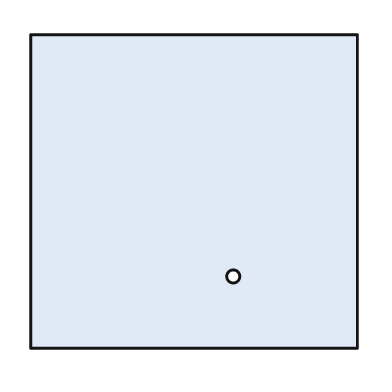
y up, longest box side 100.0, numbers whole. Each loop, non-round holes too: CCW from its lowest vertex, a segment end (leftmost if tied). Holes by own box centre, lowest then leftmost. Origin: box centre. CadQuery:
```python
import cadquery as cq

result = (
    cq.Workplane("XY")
    .moveTo(-50.0, -48.0)
    .lineTo(50.0, -48.0)
    .lineTo(50.0, 48.0)
    .lineTo(-50.0, 48.0)
    .close()
    .moveTo(12.0, -26.0)
    .circle(2.0)
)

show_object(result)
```